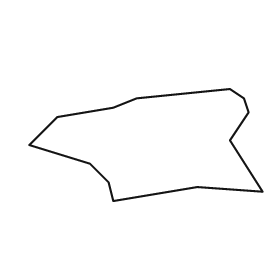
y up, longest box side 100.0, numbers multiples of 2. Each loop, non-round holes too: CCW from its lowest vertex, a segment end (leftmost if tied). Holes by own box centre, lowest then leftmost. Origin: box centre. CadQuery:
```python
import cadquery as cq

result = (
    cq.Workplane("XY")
    .moveTo(-14.0, -24.0)
    .lineTo(22.0, -18.0)
    .lineTo(50.0, -20.0)
    .lineTo(36.0, 2.0)
    .lineTo(44.0, 14.0)
    .lineTo(42.0, 20.0)
    .lineTo(36.0, 24.0)
    .lineTo(-4.0, 20.0)
    .lineTo(-14.0, 16.0)
    .lineTo(-38.0, 12.0)
    .lineTo(-50.0, 0.0)
    .lineTo(-24.0, -8.0)
    .lineTo(-16.0, -16.0)
    .close()
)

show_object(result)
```